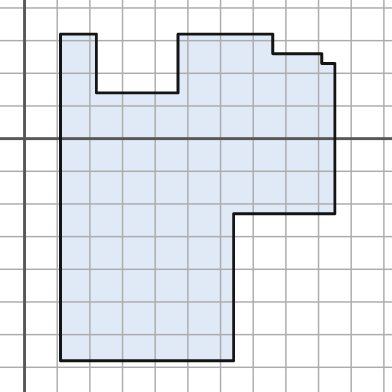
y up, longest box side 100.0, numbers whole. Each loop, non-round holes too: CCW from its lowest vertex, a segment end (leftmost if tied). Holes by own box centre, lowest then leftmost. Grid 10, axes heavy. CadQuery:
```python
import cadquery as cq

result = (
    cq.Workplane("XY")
    .moveTo(11.0, -68.0)
    .lineTo(64.0, -68.0)
    .lineTo(64.0, -23.0)
    .lineTo(95.0, -23.0)
    .lineTo(95.0, 23.0)
    .lineTo(91.0, 23.0)
    .lineTo(91.0, 26.0)
    .lineTo(76.0, 26.0)
    .lineTo(76.0, 32.0)
    .lineTo(47.0, 32.0)
    .lineTo(47.0, 14.0)
    .lineTo(22.0, 14.0)
    .lineTo(22.0, 32.0)
    .lineTo(11.0, 32.0)
    .close()
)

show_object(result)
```